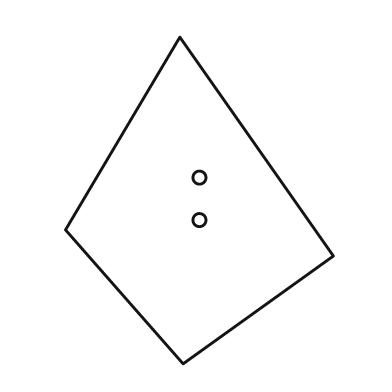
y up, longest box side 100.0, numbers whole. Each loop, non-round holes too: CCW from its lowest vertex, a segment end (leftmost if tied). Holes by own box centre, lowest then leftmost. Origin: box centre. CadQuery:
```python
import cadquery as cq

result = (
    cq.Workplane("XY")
    .moveTo(-5.0, -50.0)
    .lineTo(41.0, -17.0)
    .lineTo(-6.0, 50.0)
    .lineTo(-41.0, -9.0)
    .close()
    .moveTo(0.0, -6.0)
    .circle(2.0)
    .moveTo(0.0, 7.0)
    .circle(2.0)
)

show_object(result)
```